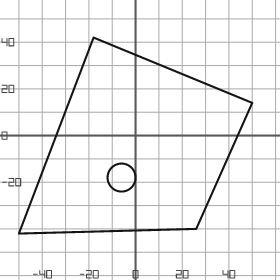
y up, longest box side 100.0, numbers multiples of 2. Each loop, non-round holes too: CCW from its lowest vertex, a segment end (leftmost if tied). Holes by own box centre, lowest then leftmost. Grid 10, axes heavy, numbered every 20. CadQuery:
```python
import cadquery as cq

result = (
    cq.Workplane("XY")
    .moveTo(-50.0, -42.0)
    .lineTo(26.0, -40.0)
    .lineTo(50.0, 14.0)
    .lineTo(-18.0, 42.0)
    .close()
    .moveTo(-6.0, -18.0)
    .circle(6.0)
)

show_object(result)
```